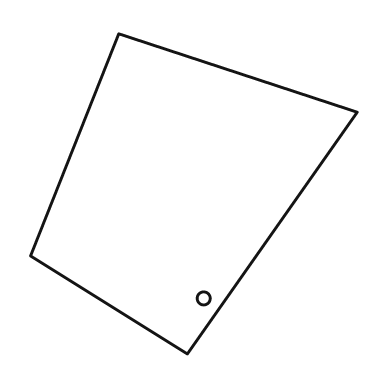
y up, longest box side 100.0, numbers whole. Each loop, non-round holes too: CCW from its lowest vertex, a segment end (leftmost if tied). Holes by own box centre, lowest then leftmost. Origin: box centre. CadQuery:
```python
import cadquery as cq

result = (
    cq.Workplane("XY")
    .moveTo(-2.0, -49.0)
    .lineTo(50.0, 25.0)
    .lineTo(-23.0, 49.0)
    .lineTo(-50.0, -19.0)
    .close()
    .moveTo(3.0, -32.0)
    .circle(2.0)
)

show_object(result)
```